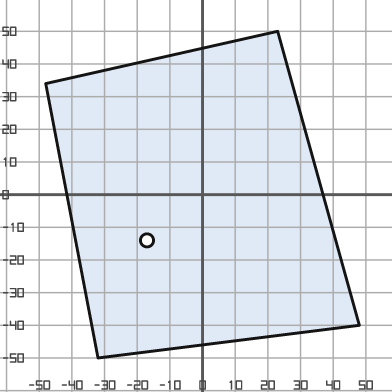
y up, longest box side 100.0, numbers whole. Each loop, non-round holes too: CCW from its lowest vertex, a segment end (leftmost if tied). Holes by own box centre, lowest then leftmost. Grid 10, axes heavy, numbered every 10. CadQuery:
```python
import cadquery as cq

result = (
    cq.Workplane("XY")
    .moveTo(-32.0, -50.0)
    .lineTo(48.0, -40.0)
    .lineTo(23.0, 50.0)
    .lineTo(-48.0, 34.0)
    .close()
    .moveTo(-17.0, -14.0)
    .circle(2.0)
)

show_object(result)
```